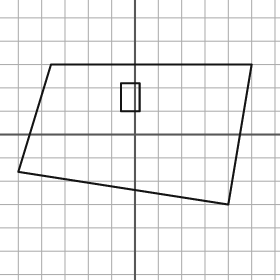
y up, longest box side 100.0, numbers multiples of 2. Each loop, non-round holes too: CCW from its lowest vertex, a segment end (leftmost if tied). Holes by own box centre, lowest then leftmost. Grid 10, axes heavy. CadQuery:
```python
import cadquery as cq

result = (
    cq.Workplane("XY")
    .moveTo(40.0, -30.0)
    .lineTo(50.0, 30.0)
    .lineTo(-36.0, 30.0)
    .lineTo(-50.0, -16.0)
    .close()
    .moveTo(-6.0, 10.0)
    .lineTo(2.0, 10.0)
    .lineTo(2.0, 22.0)
    .lineTo(-6.0, 22.0)
    .close()
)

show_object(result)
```